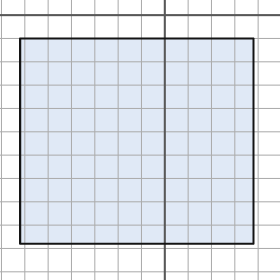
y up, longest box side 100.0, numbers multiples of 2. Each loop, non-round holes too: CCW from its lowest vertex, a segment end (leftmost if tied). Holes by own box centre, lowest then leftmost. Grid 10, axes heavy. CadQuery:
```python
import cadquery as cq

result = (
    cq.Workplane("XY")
    .moveTo(-62.0, -98.0)
    .lineTo(38.0, -98.0)
    .lineTo(38.0, -10.0)
    .lineTo(-62.0, -10.0)
    .close()
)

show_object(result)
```